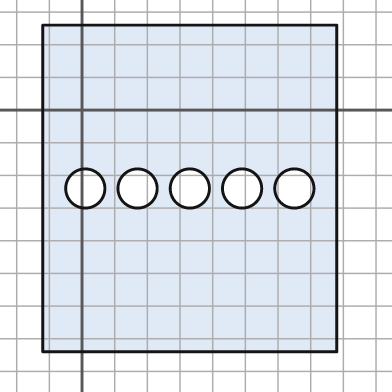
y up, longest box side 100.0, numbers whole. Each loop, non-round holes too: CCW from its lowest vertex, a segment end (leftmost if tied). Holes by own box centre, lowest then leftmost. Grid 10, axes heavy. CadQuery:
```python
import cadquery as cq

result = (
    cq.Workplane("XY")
    .moveTo(-12.0, -74.0)
    .lineTo(78.0, -74.0)
    .lineTo(78.0, 26.0)
    .lineTo(-12.0, 26.0)
    .close()
    .moveTo(1.0, -24.0)
    .circle(6.0)
    .moveTo(17.0, -24.0)
    .circle(6.0)
    .moveTo(33.0, -24.0)
    .circle(6.0)
    .moveTo(49.0, -24.0)
    .circle(6.0)
    .moveTo(65.0, -24.0)
    .circle(6.0)
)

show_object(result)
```